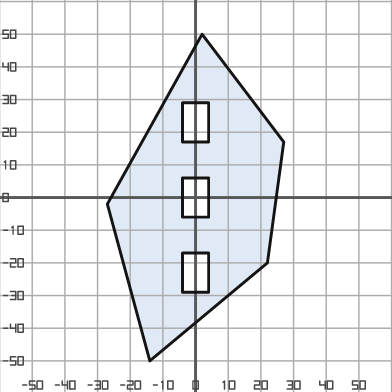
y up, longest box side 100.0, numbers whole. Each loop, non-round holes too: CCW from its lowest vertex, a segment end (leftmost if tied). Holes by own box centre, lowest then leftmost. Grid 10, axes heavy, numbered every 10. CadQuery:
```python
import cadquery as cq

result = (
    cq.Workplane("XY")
    .moveTo(-14.0, -50.0)
    .lineTo(22.0, -20.0)
    .lineTo(27.0, 17.0)
    .lineTo(2.0, 50.0)
    .lineTo(-27.0, -2.0)
    .close()
    .moveTo(-4.0, -29.0)
    .lineTo(4.0, -29.0)
    .lineTo(4.0, -17.0)
    .lineTo(-4.0, -17.0)
    .close()
    .moveTo(-4.0, -6.0)
    .lineTo(4.0, -6.0)
    .lineTo(4.0, 6.0)
    .lineTo(-4.0, 6.0)
    .close()
    .moveTo(-4.0, 17.0)
    .lineTo(4.0, 17.0)
    .lineTo(4.0, 29.0)
    .lineTo(-4.0, 29.0)
    .close()
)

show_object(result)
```